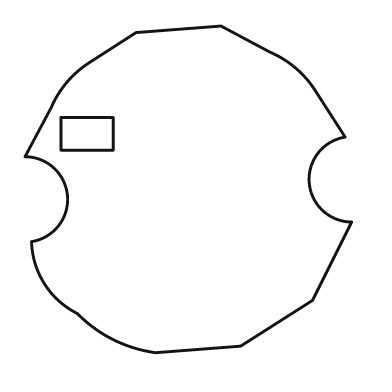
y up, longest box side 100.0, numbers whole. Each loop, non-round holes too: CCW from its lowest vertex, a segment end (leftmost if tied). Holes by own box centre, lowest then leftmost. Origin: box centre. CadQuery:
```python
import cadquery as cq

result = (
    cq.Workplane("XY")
    .moveTo(-10.0, -50.0)
    .lineTo(16.0, -48.0)
    .lineTo(38.0, -34.0)
    .lineTo(50.0, -10.0)
    .threePointArc((37.0, 2.0), (48.0, 16.0))
    .lineTo(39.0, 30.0)
    .threePointArc((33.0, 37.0), (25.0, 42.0))
    .lineTo(10.0, 50.0)
    .lineTo(-16.0, 48.0)
    .lineTo(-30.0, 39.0)
    .threePointArc((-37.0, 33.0), (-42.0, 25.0))
    .lineTo(-50.0, 10.0)
    .threePointArc((-37.0, -2.0), (-48.0, -16.0))
    .threePointArc((-44.0, -29.0), (-34.0, -38.0))
    .threePointArc((-23.0, -46.0), (-10.0, -50.0))
    .close()
    .moveTo(-39.0, 12.0)
    .lineTo(-23.0, 12.0)
    .lineTo(-23.0, 22.0)
    .lineTo(-39.0, 22.0)
    .close()
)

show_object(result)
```